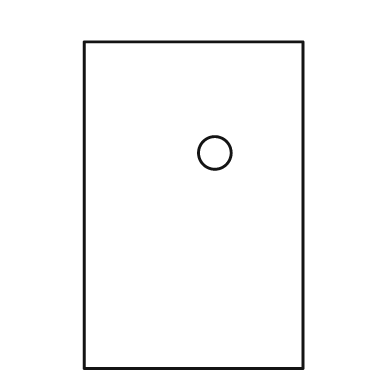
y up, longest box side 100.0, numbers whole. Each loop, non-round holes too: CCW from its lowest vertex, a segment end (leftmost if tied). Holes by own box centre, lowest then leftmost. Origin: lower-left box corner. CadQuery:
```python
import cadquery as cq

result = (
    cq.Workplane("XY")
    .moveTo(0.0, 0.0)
    .lineTo(67.0, 0.0)
    .lineTo(67.0, 100.0)
    .lineTo(0.0, 100.0)
    .close()
    .moveTo(40.0, 66.0)
    .circle(5.0)
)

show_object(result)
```